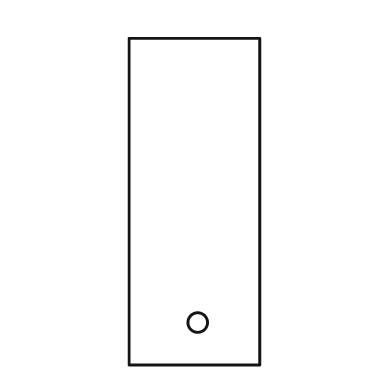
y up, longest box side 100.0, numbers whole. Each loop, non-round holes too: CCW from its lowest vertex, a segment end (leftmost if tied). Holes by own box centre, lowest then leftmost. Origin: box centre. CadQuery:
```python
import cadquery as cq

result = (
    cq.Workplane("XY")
    .moveTo(-20.0, -50.0)
    .lineTo(20.0, -50.0)
    .lineTo(20.0, 50.0)
    .lineTo(-20.0, 50.0)
    .close()
    .moveTo(1.0, -37.0)
    .circle(3.0)
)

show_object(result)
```